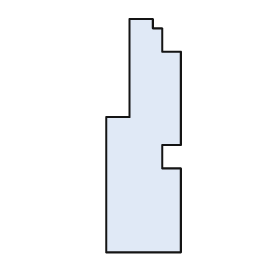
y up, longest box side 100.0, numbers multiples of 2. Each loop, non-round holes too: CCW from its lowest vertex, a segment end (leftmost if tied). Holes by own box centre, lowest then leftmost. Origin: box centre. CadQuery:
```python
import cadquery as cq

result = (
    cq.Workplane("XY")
    .moveTo(-16.0, -50.0)
    .lineTo(16.0, -50.0)
    .lineTo(16.0, -14.0)
    .lineTo(8.0, -14.0)
    .lineTo(8.0, -4.0)
    .lineTo(16.0, -4.0)
    .lineTo(16.0, 36.0)
    .lineTo(8.0, 36.0)
    .lineTo(8.0, 46.0)
    .lineTo(4.0, 46.0)
    .lineTo(4.0, 50.0)
    .lineTo(-6.0, 50.0)
    .lineTo(-6.0, 8.0)
    .lineTo(-16.0, 8.0)
    .close()
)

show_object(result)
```